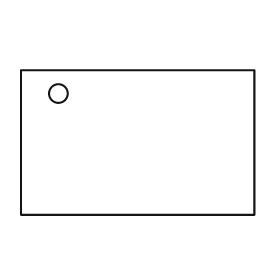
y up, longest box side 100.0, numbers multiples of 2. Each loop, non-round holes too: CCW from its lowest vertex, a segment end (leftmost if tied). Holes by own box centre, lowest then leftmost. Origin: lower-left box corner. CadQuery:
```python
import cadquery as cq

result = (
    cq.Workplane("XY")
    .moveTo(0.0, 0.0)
    .lineTo(100.0, 0.0)
    .lineTo(100.0, 62.0)
    .lineTo(0.0, 62.0)
    .close()
    .moveTo(16.0, 52.0)
    .circle(4.0)
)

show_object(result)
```